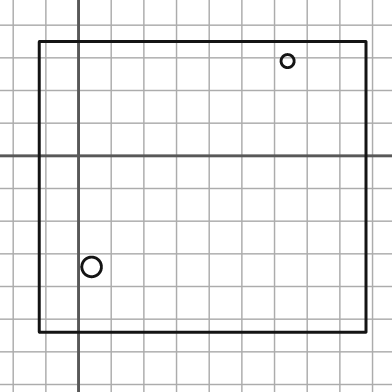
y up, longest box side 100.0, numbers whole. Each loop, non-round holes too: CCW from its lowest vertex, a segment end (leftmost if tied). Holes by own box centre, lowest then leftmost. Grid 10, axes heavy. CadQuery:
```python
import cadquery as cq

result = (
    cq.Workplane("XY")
    .moveTo(-12.0, -54.0)
    .lineTo(88.0, -54.0)
    .lineTo(88.0, 35.0)
    .lineTo(-12.0, 35.0)
    .close()
    .moveTo(4.0, -34.0)
    .circle(3.0)
    .moveTo(64.0, 29.0)
    .circle(2.0)
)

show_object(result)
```